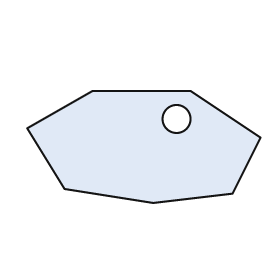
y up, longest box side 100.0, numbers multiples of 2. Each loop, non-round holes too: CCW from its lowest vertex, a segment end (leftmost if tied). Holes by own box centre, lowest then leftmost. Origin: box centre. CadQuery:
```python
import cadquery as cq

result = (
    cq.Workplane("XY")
    .moveTo(4.0, -24.0)
    .lineTo(38.0, -20.0)
    .lineTo(50.0, 4.0)
    .lineTo(20.0, 24.0)
    .lineTo(-22.0, 24.0)
    .lineTo(-50.0, 8.0)
    .lineTo(-34.0, -18.0)
    .close()
    .moveTo(14.0, 12.0)
    .circle(6.0)
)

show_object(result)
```